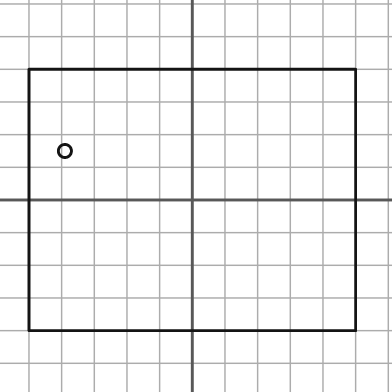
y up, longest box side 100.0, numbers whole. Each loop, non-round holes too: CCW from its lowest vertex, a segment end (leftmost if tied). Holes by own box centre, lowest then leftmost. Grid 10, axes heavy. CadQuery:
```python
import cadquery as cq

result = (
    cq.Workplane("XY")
    .moveTo(-50.0, -40.0)
    .lineTo(50.0, -40.0)
    .lineTo(50.0, 40.0)
    .lineTo(-50.0, 40.0)
    .close()
    .moveTo(-39.0, 15.0)
    .circle(2.0)
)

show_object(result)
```